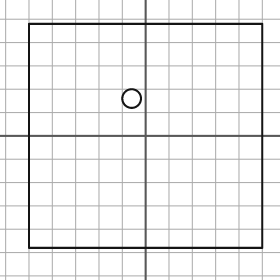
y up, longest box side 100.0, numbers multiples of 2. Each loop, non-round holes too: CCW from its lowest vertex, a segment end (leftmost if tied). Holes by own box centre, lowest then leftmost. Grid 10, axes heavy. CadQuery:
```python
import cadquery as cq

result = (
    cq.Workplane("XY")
    .moveTo(-50.0, -48.0)
    .lineTo(50.0, -48.0)
    .lineTo(50.0, 48.0)
    .lineTo(-50.0, 48.0)
    .close()
    .moveTo(-6.0, 16.0)
    .circle(4.0)
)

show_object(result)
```